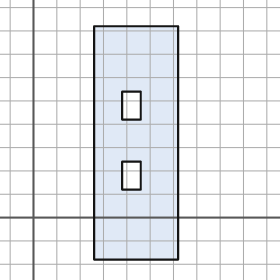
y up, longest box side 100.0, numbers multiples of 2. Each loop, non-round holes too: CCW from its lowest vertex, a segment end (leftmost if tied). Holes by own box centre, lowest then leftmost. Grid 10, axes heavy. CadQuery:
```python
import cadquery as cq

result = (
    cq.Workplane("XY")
    .moveTo(26.0, -18.0)
    .lineTo(62.0, -18.0)
    .lineTo(62.0, 82.0)
    .lineTo(26.0, 82.0)
    .close()
    .moveTo(38.0, 12.0)
    .lineTo(46.0, 12.0)
    .lineTo(46.0, 24.0)
    .lineTo(38.0, 24.0)
    .close()
    .moveTo(38.0, 42.0)
    .lineTo(46.0, 42.0)
    .lineTo(46.0, 54.0)
    .lineTo(38.0, 54.0)
    .close()
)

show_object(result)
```